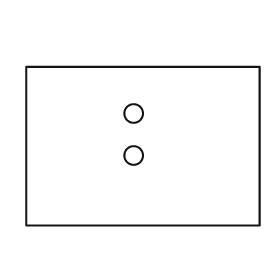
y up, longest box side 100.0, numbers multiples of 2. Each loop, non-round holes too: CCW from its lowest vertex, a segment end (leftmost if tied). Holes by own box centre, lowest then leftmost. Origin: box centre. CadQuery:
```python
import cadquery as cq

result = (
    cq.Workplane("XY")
    .moveTo(-50.0, -34.0)
    .lineTo(50.0, -34.0)
    .lineTo(50.0, 34.0)
    .lineTo(-50.0, 34.0)
    .close()
    .moveTo(-4.0, -4.0)
    .circle(4.0)
    .moveTo(-4.0, 14.0)
    .circle(4.0)
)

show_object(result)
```